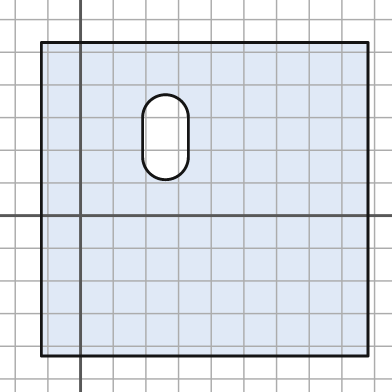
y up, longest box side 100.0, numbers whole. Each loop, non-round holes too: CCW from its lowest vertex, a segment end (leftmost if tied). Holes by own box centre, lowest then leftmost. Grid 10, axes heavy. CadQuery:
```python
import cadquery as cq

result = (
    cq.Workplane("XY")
    .moveTo(-12.0, -43.0)
    .lineTo(88.0, -43.0)
    .lineTo(88.0, 53.0)
    .lineTo(-12.0, 53.0)
    .close()
    .moveTo(19.0, 18.0)
    .threePointArc((26.0, 11.0), (33.0, 18.0))
    .lineTo(33.0, 30.0)
    .threePointArc((26.0, 37.0), (19.0, 30.0))
    .close()
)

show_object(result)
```